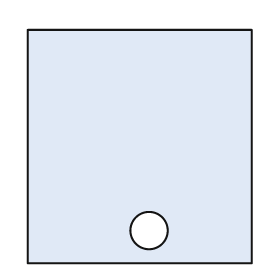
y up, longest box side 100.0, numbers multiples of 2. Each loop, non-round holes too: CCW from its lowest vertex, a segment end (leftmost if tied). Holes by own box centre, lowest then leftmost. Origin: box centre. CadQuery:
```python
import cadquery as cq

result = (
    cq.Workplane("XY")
    .moveTo(-48.0, -50.0)
    .lineTo(48.0, -50.0)
    .lineTo(48.0, 50.0)
    .lineTo(-48.0, 50.0)
    .close()
    .moveTo(4.0, -36.0)
    .circle(8.0)
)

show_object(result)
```